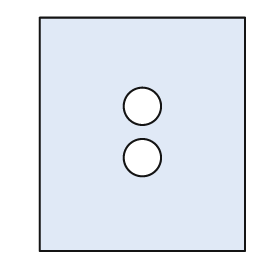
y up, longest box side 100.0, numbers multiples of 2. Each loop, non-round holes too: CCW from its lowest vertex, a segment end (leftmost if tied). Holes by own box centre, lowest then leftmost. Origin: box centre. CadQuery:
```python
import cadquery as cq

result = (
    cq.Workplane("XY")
    .moveTo(-44.0, -50.0)
    .lineTo(44.0, -50.0)
    .lineTo(44.0, 50.0)
    .lineTo(-44.0, 50.0)
    .close()
    .moveTo(0.0, -10.0)
    .circle(8.0)
    .moveTo(0.0, 12.0)
    .circle(8.0)
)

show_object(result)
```